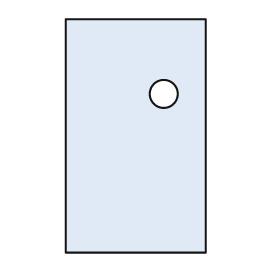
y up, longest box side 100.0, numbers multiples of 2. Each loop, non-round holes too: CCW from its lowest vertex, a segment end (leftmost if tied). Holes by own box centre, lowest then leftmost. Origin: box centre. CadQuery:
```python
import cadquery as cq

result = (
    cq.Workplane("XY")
    .moveTo(-30.0, -50.0)
    .lineTo(30.0, -50.0)
    .lineTo(30.0, 50.0)
    .lineTo(-30.0, 50.0)
    .close()
    .moveTo(12.0, 18.0)
    .circle(6.0)
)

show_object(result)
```